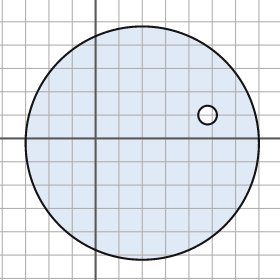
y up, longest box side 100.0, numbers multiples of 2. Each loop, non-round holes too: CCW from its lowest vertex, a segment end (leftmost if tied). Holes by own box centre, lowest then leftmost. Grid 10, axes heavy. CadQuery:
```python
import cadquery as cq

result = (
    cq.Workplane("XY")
    .moveTo(20.0, -2.0)
    .circle(50.0)
    .moveTo(48.0, 10.0)
    .circle(4.0)
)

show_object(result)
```